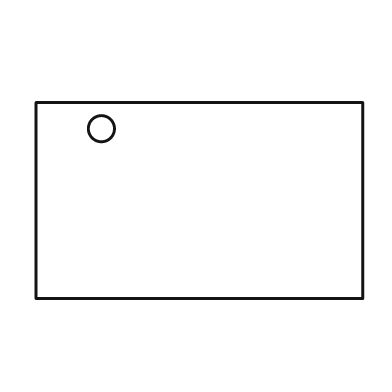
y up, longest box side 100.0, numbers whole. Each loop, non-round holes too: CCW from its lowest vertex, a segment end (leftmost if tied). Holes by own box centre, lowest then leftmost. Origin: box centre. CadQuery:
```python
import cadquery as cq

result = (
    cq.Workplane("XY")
    .moveTo(-50.0, -30.0)
    .lineTo(50.0, -30.0)
    .lineTo(50.0, 30.0)
    .lineTo(-50.0, 30.0)
    .close()
    .moveTo(-30.0, 22.0)
    .circle(4.0)
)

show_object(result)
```